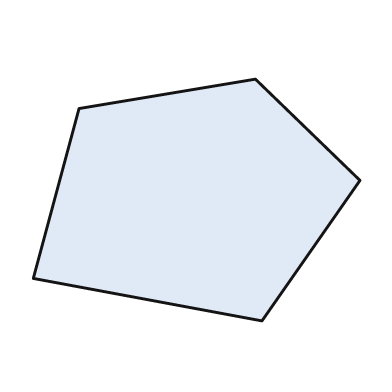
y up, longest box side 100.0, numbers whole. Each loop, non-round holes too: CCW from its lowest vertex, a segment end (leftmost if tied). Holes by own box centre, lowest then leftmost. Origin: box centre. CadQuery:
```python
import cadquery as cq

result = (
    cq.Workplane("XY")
    .moveTo(20.0, -37.0)
    .lineTo(50.0, 6.0)
    .lineTo(18.0, 37.0)
    .lineTo(-36.0, 28.0)
    .lineTo(-50.0, -24.0)
    .close()
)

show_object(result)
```